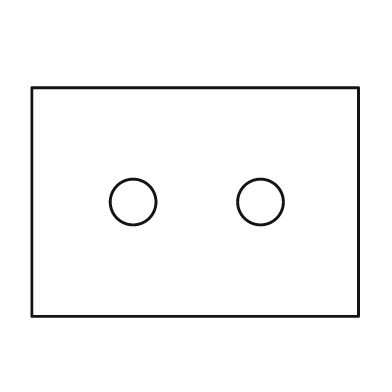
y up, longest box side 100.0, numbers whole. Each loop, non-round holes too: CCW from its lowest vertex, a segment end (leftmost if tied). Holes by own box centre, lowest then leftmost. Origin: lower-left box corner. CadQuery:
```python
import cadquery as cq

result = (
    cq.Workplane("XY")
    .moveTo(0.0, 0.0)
    .lineTo(100.0, 0.0)
    .lineTo(100.0, 70.0)
    .lineTo(0.0, 70.0)
    .close()
    .moveTo(31.0, 35.0)
    .circle(7.0)
    .moveTo(70.0, 35.0)
    .circle(7.0)
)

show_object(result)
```